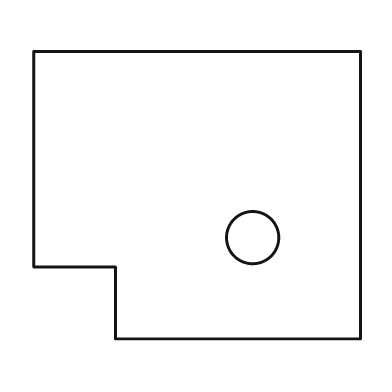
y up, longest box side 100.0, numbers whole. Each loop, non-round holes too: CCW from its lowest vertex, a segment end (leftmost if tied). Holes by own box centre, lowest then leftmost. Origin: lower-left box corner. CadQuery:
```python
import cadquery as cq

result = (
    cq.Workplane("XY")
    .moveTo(25.0, 0.0)
    .lineTo(100.0, 0.0)
    .lineTo(100.0, 88.0)
    .lineTo(0.0, 88.0)
    .lineTo(0.0, 22.0)
    .lineTo(25.0, 22.0)
    .close()
    .moveTo(67.0, 31.0)
    .circle(8.0)
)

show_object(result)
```